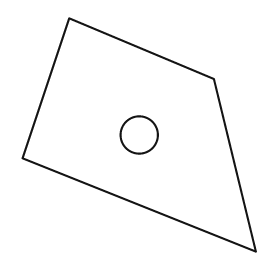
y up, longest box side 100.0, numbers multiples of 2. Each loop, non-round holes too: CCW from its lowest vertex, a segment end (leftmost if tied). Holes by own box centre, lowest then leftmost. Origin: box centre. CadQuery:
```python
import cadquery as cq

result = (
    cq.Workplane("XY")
    .moveTo(50.0, -50.0)
    .lineTo(32.0, 24.0)
    .lineTo(-30.0, 50.0)
    .lineTo(-50.0, -10.0)
    .close()
    .moveTo(0.0, 0.0)
    .circle(8.0)
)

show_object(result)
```